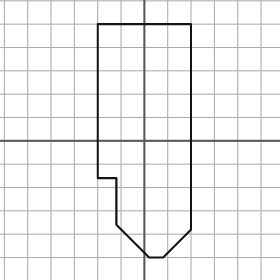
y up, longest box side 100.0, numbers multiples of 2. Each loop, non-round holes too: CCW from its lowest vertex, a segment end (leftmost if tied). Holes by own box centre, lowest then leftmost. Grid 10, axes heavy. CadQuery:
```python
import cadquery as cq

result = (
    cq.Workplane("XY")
    .moveTo(2.0, -50.0)
    .lineTo(8.0, -50.0)
    .lineTo(20.0, -38.0)
    .lineTo(20.0, 50.0)
    .lineTo(-20.0, 50.0)
    .lineTo(-20.0, -16.0)
    .lineTo(-12.0, -16.0)
    .lineTo(-12.0, -36.0)
    .close()
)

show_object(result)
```